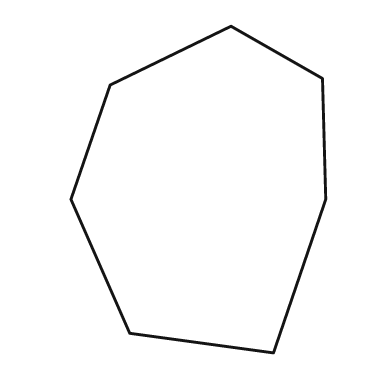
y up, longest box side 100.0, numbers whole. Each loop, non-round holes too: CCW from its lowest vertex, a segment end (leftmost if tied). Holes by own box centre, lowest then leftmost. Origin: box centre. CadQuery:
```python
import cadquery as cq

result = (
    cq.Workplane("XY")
    .moveTo(23.0, -50.0)
    .lineTo(39.0, -3.0)
    .lineTo(38.0, 34.0)
    .lineTo(10.0, 50.0)
    .lineTo(-27.0, 32.0)
    .lineTo(-39.0, -3.0)
    .lineTo(-21.0, -44.0)
    .close()
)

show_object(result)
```